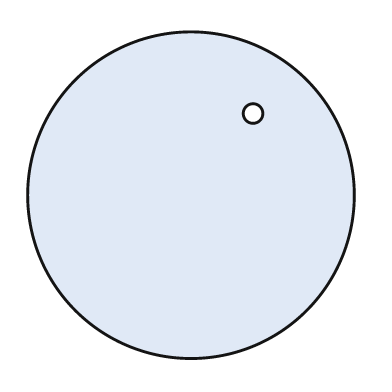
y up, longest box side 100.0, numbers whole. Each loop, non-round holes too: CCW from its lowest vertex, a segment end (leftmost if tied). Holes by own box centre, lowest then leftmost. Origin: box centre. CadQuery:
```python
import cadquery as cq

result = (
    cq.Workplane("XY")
    .moveTo(0.0, 0.0)
    .circle(50.0)
    .moveTo(19.0, 25.0)
    .circle(3.0)
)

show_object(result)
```